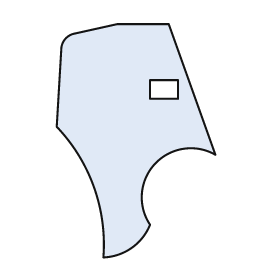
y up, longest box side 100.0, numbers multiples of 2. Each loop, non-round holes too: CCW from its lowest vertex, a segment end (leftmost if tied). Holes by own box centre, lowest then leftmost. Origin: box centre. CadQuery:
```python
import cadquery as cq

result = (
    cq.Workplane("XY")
    .moveTo(-14.0, -50.0)
    .threePointArc((-2.0, -46.0), (6.0, -36.0))
    .threePointArc((8.0, -10.0), (34.0, -6.0))
    .lineTo(14.0, 50.0)
    .lineTo(-8.0, 50.0)
    .lineTo(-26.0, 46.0)
    .threePointArc((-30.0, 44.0), (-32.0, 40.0))
    .lineTo(-34.0, 6.0)
    .threePointArc((-18.0, -20.0), (-14.0, -50.0))
    .close()
    .moveTo(6.0, 18.0)
    .lineTo(18.0, 18.0)
    .lineTo(18.0, 26.0)
    .lineTo(6.0, 26.0)
    .close()
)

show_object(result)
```